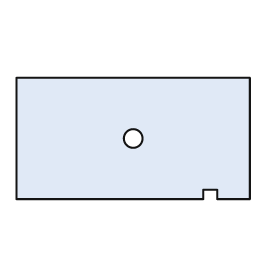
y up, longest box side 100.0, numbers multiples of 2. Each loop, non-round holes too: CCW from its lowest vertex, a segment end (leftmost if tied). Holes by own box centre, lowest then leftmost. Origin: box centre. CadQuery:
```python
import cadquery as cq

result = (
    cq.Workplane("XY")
    .moveTo(-50.0, -26.0)
    .lineTo(30.0, -26.0)
    .lineTo(30.0, -22.0)
    .lineTo(36.0, -22.0)
    .lineTo(36.0, -26.0)
    .lineTo(50.0, -26.0)
    .lineTo(50.0, 26.0)
    .lineTo(-50.0, 26.0)
    .close()
    .moveTo(0.0, 0.0)
    .circle(4.0)
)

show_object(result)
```